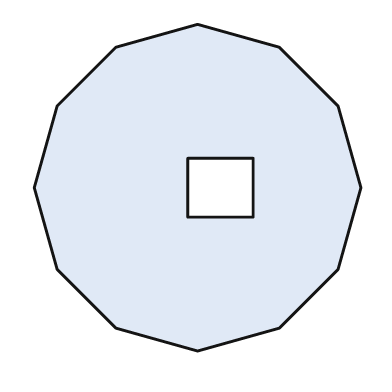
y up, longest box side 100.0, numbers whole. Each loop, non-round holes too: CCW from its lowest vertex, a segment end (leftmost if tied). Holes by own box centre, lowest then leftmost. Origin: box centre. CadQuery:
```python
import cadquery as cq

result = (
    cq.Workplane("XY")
    .moveTo(0.0, -50.0)
    .lineTo(25.0, -43.0)
    .lineTo(43.0, -25.0)
    .lineTo(50.0, 0.0)
    .lineTo(43.0, 25.0)
    .lineTo(25.0, 43.0)
    .lineTo(0.0, 50.0)
    .lineTo(-25.0, 43.0)
    .lineTo(-43.0, 25.0)
    .lineTo(-50.0, 0.0)
    .lineTo(-43.0, -25.0)
    .lineTo(-25.0, -43.0)
    .close()
    .moveTo(-3.0, -9.0)
    .lineTo(17.0, -9.0)
    .lineTo(17.0, 9.0)
    .lineTo(-3.0, 9.0)
    .close()
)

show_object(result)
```